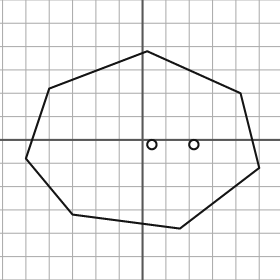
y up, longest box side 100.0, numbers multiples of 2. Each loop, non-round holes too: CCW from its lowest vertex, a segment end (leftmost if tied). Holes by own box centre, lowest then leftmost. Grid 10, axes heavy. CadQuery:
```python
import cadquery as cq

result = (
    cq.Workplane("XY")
    .moveTo(16.0, -38.0)
    .lineTo(50.0, -12.0)
    .lineTo(42.0, 20.0)
    .lineTo(2.0, 38.0)
    .lineTo(-40.0, 22.0)
    .lineTo(-50.0, -8.0)
    .lineTo(-30.0, -32.0)
    .close()
    .moveTo(4.0, -2.0)
    .circle(2.0)
    .moveTo(22.0, -2.0)
    .circle(2.0)
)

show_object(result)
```